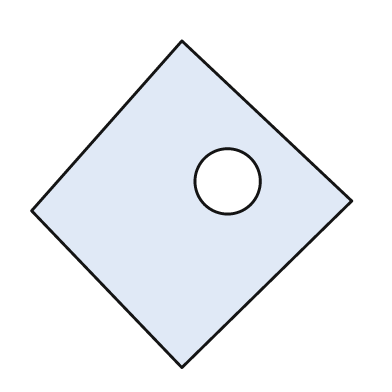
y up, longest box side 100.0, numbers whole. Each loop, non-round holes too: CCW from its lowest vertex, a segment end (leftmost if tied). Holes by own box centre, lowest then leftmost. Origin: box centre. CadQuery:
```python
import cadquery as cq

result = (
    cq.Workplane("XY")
    .moveTo(-3.0, -50.0)
    .lineTo(49.0, 1.0)
    .lineTo(-3.0, 50.0)
    .lineTo(-49.0, -2.0)
    .close()
    .moveTo(11.0, 7.0)
    .circle(10.0)
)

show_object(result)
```